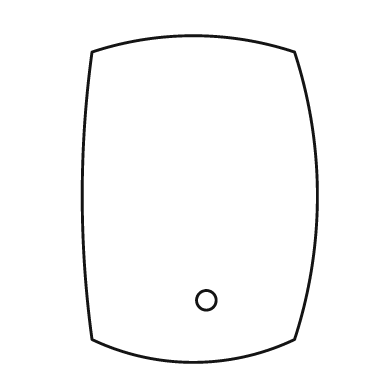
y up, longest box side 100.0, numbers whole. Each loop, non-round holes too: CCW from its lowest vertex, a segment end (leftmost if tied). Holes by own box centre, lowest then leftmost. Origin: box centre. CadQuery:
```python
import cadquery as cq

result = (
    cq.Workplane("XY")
    .moveTo(-33.0, -43.0)
    .threePointArc((-2.0, -50.0), (29.0, -43.0))
    .threePointArc((36.0, 1.0), (29.0, 45.0))
    .threePointArc((-2.0, 50.0), (-33.0, 45.0))
    .threePointArc((-36.0, 1.0), (-33.0, -43.0))
    .close()
    .moveTo(2.0, -31.0)
    .circle(3.0)
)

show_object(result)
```